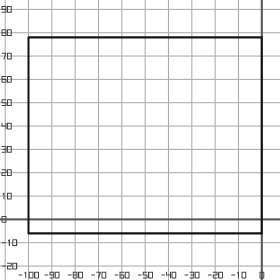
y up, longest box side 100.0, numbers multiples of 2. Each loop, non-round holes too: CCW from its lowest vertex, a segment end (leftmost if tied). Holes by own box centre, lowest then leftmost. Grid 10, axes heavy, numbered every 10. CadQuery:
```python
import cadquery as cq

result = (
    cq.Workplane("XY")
    .moveTo(-100.0, -6.0)
    .lineTo(0.0, -6.0)
    .lineTo(0.0, 78.0)
    .lineTo(-100.0, 78.0)
    .close()
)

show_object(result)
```